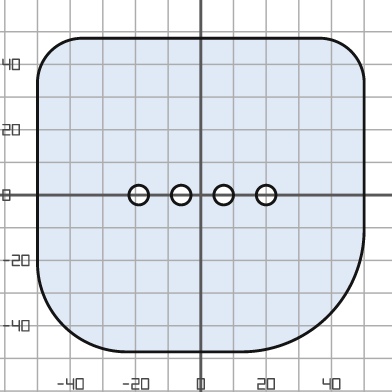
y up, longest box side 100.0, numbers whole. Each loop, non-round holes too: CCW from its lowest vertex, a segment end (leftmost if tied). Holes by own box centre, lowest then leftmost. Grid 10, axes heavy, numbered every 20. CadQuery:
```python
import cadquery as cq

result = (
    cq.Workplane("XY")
    .moveTo(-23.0, -48.0)
    .lineTo(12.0, -48.0)
    .threePointArc((39.0, -37.0), (50.0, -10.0))
    .lineTo(50.0, 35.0)
    .threePointArc((46.0, 44.0), (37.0, 48.0))
    .lineTo(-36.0, 48.0)
    .threePointArc((-46.0, 44.0), (-50.0, 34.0))
    .lineTo(-50.0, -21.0)
    .threePointArc((-42.0, -40.0), (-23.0, -48.0))
    .close()
    .moveTo(-19.0, 0.0)
    .circle(3.0)
    .moveTo(-6.0, 0.0)
    .circle(3.0)
    .moveTo(7.0, 0.0)
    .circle(3.0)
    .moveTo(20.0, 0.0)
    .circle(3.0)
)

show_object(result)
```